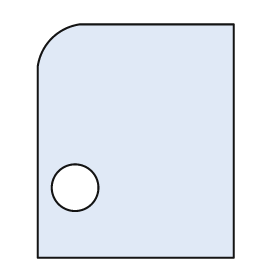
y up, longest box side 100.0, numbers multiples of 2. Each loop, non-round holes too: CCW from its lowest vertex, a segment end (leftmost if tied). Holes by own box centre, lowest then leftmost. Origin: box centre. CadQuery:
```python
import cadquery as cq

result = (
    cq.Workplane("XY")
    .moveTo(-42.0, -50.0)
    .lineTo(42.0, -50.0)
    .lineTo(42.0, 50.0)
    .lineTo(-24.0, 50.0)
    .threePointArc((-36.0, 44.0), (-42.0, 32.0))
    .close()
    .moveTo(-26.0, -20.0)
    .circle(10.0)
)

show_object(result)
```